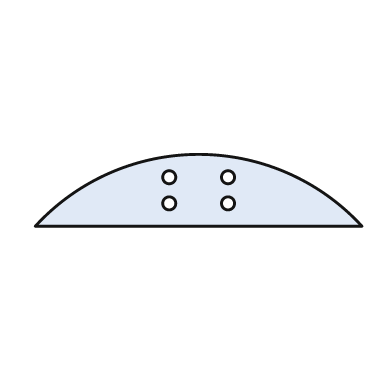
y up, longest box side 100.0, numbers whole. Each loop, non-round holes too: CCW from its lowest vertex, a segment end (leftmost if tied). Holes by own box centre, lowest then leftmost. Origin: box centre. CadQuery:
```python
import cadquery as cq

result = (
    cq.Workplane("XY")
    .moveTo(-50.0, -11.0)
    .lineTo(50.0, -11.0)
    .threePointArc((0.0, 11.0), (-50.0, -11.0))
    .close()
    .moveTo(-9.0, -4.0)
    .circle(2.0)
    .moveTo(9.0, -4.0)
    .circle(2.0)
    .moveTo(-9.0, 4.0)
    .circle(2.0)
    .moveTo(9.0, 4.0)
    .circle(2.0)
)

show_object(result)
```